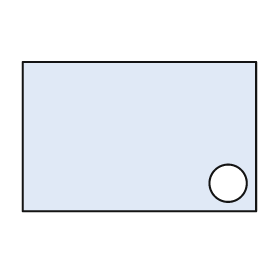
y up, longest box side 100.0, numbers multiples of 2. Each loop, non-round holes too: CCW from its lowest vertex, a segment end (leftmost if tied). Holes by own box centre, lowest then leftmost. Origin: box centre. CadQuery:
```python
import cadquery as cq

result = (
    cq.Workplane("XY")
    .moveTo(-50.0, -32.0)
    .lineTo(50.0, -32.0)
    .lineTo(50.0, 32.0)
    .lineTo(-50.0, 32.0)
    .close()
    .moveTo(38.0, -20.0)
    .circle(8.0)
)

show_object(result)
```